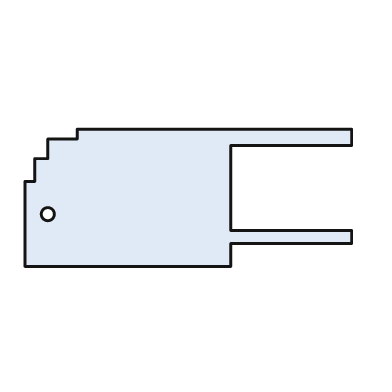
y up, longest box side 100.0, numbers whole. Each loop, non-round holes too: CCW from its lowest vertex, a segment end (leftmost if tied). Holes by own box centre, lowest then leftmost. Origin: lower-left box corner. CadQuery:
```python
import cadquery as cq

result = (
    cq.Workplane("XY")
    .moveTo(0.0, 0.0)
    .lineTo(63.0, 0.0)
    .lineTo(63.0, 7.0)
    .lineTo(100.0, 7.0)
    .lineTo(100.0, 11.0)
    .lineTo(63.0, 11.0)
    .lineTo(63.0, 37.0)
    .lineTo(100.0, 37.0)
    .lineTo(100.0, 42.0)
    .lineTo(16.0, 42.0)
    .lineTo(16.0, 39.0)
    .lineTo(7.0, 39.0)
    .lineTo(7.0, 33.0)
    .lineTo(3.0, 33.0)
    .lineTo(3.0, 26.0)
    .lineTo(0.0, 26.0)
    .close()
    .moveTo(7.0, 16.0)
    .circle(2.0)
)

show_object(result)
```